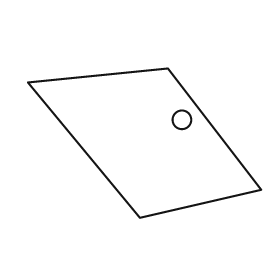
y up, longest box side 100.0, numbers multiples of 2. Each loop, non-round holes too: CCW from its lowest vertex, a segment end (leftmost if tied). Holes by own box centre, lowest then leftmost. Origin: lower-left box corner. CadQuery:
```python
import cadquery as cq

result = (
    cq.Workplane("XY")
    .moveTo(48.0, 0.0)
    .lineTo(100.0, 12.0)
    .lineTo(60.0, 64.0)
    .lineTo(0.0, 58.0)
    .close()
    .moveTo(66.0, 42.0)
    .circle(4.0)
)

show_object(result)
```